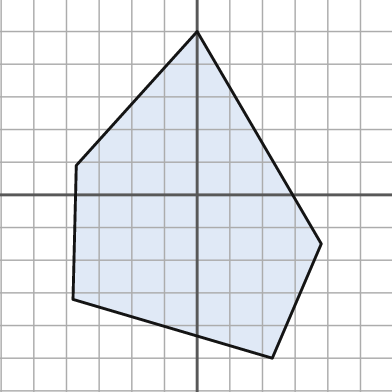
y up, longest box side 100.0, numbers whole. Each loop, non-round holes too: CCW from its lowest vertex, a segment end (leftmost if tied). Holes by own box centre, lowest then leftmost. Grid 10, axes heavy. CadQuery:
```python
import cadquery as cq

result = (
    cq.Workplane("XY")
    .moveTo(23.0, -50.0)
    .lineTo(38.0, -15.0)
    .lineTo(0.0, 50.0)
    .lineTo(-37.0, 9.0)
    .lineTo(-38.0, -32.0)
    .close()
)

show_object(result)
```